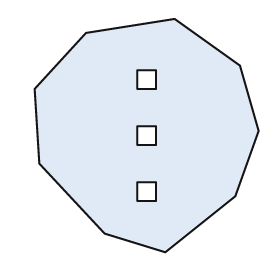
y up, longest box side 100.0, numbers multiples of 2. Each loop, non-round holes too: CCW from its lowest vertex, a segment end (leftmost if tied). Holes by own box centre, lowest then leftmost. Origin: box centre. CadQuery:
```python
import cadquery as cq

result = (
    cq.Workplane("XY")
    .moveTo(8.0, -50.0)
    .lineTo(38.0, -26.0)
    .lineTo(48.0, 2.0)
    .lineTo(40.0, 30.0)
    .lineTo(12.0, 50.0)
    .lineTo(-26.0, 44.0)
    .lineTo(-48.0, 20.0)
    .lineTo(-46.0, -12.0)
    .lineTo(-18.0, -42.0)
    .close()
    .moveTo(-4.0, -28.0)
    .lineTo(4.0, -28.0)
    .lineTo(4.0, -20.0)
    .lineTo(-4.0, -20.0)
    .close()
    .moveTo(-4.0, -4.0)
    .lineTo(4.0, -4.0)
    .lineTo(4.0, 4.0)
    .lineTo(-4.0, 4.0)
    .close()
    .moveTo(-4.0, 20.0)
    .lineTo(4.0, 20.0)
    .lineTo(4.0, 28.0)
    .lineTo(-4.0, 28.0)
    .close()
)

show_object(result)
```